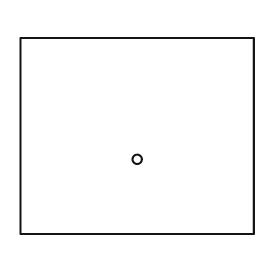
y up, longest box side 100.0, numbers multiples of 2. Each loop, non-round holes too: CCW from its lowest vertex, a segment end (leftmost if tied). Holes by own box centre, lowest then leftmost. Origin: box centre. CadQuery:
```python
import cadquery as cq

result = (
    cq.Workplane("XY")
    .moveTo(-50.0, -42.0)
    .lineTo(50.0, -42.0)
    .lineTo(50.0, 42.0)
    .lineTo(-50.0, 42.0)
    .close()
    .moveTo(0.0, -10.0)
    .circle(2.0)
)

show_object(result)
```